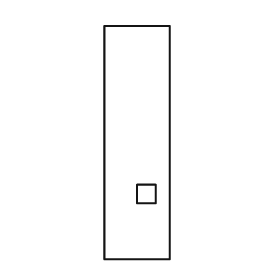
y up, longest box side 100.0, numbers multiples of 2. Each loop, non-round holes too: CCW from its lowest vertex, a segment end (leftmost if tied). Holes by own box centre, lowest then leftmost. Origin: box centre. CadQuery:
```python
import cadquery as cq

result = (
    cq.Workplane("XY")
    .moveTo(-14.0, -50.0)
    .lineTo(14.0, -50.0)
    .lineTo(14.0, 50.0)
    .lineTo(-14.0, 50.0)
    .close()
    .moveTo(0.0, -26.0)
    .lineTo(8.0, -26.0)
    .lineTo(8.0, -18.0)
    .lineTo(0.0, -18.0)
    .close()
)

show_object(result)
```